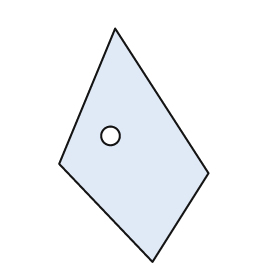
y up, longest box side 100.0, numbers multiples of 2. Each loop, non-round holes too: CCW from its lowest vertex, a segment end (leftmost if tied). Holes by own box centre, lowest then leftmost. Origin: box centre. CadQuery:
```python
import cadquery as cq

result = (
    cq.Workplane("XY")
    .moveTo(8.0, -50.0)
    .lineTo(32.0, -12.0)
    .lineTo(-8.0, 50.0)
    .lineTo(-32.0, -8.0)
    .close()
    .moveTo(-10.0, 4.0)
    .circle(4.0)
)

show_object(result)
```